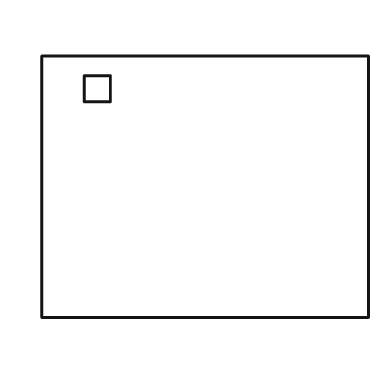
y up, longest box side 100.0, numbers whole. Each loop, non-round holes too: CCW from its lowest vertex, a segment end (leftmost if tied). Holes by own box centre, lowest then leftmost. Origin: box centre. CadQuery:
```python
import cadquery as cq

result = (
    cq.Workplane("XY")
    .moveTo(-50.0, -40.0)
    .lineTo(50.0, -40.0)
    .lineTo(50.0, 40.0)
    .lineTo(-50.0, 40.0)
    .close()
    .moveTo(-37.0, 26.0)
    .lineTo(-29.0, 26.0)
    .lineTo(-29.0, 34.0)
    .lineTo(-37.0, 34.0)
    .close()
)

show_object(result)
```